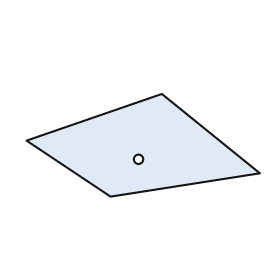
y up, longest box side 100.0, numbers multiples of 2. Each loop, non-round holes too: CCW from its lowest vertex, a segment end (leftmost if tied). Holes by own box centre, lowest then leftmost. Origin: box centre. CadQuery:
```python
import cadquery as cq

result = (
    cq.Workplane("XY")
    .moveTo(-14.0, -22.0)
    .lineTo(50.0, -12.0)
    .lineTo(8.0, 22.0)
    .lineTo(-50.0, 2.0)
    .close()
    .moveTo(-2.0, -6.0)
    .circle(2.0)
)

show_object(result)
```